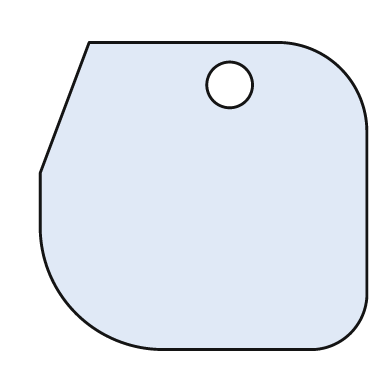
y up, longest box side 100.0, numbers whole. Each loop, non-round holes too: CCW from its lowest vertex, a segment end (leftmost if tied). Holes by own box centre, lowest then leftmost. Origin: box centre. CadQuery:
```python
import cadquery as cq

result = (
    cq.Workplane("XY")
    .moveTo(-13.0, -47.0)
    .lineTo(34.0, -47.0)
    .threePointArc((45.0, -42.0), (50.0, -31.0))
    .lineTo(50.0, 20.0)
    .threePointArc((42.0, 39.0), (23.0, 47.0))
    .lineTo(-35.0, 47.0)
    .lineTo(-50.0, 7.0)
    .lineTo(-50.0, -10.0)
    .threePointArc((-39.0, -36.0), (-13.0, -47.0))
    .close()
    .moveTo(8.0, 34.0)
    .circle(7.0)
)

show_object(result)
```